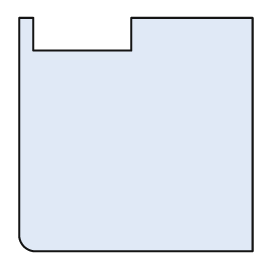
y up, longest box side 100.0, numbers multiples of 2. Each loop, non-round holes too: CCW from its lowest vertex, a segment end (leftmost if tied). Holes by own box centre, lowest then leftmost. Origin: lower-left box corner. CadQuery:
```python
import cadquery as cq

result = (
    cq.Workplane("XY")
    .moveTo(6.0, 0.0)
    .lineTo(100.0, 0.0)
    .lineTo(100.0, 100.0)
    .lineTo(48.0, 100.0)
    .lineTo(48.0, 86.0)
    .lineTo(6.0, 86.0)
    .lineTo(6.0, 100.0)
    .lineTo(0.0, 100.0)
    .lineTo(0.0, 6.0)
    .threePointArc((2.0, 2.0), (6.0, 0.0))
    .close()
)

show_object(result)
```